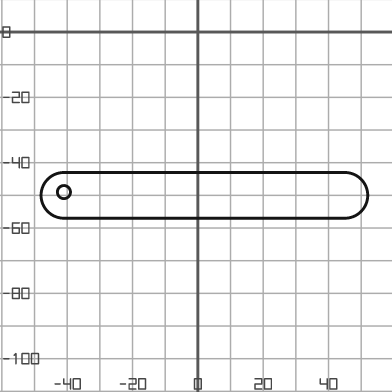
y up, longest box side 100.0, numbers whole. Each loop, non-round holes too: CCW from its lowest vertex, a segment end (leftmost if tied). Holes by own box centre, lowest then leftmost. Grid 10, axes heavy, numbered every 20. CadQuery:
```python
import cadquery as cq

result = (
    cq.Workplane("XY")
    .moveTo(-41.0, -57.0)
    .lineTo(45.0, -57.0)
    .threePointArc((52.0, -50.0), (45.0, -43.0))
    .lineTo(-41.0, -43.0)
    .threePointArc((-48.0, -50.0), (-41.0, -57.0))
    .close()
    .moveTo(-41.0, -49.0)
    .circle(2.0)
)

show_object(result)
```